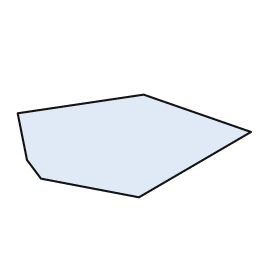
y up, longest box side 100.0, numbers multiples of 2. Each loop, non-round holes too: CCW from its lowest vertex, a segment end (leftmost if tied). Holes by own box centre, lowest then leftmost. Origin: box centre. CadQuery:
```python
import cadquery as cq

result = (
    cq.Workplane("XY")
    .moveTo(2.0, -22.0)
    .lineTo(50.0, 6.0)
    .lineTo(4.0, 22.0)
    .lineTo(-50.0, 14.0)
    .lineTo(-46.0, -6.0)
    .lineTo(-40.0, -14.0)
    .close()
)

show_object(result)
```